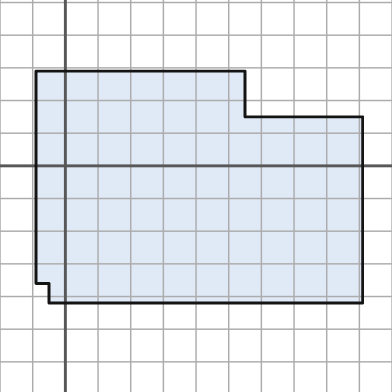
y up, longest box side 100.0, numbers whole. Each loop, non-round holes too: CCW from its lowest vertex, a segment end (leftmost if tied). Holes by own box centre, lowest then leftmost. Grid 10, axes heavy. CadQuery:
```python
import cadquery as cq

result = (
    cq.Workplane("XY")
    .moveTo(-5.0, -42.0)
    .lineTo(91.0, -42.0)
    .lineTo(91.0, 15.0)
    .lineTo(55.0, 15.0)
    .lineTo(55.0, 29.0)
    .lineTo(-9.0, 29.0)
    .lineTo(-9.0, -36.0)
    .lineTo(-5.0, -36.0)
    .close()
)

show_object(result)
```